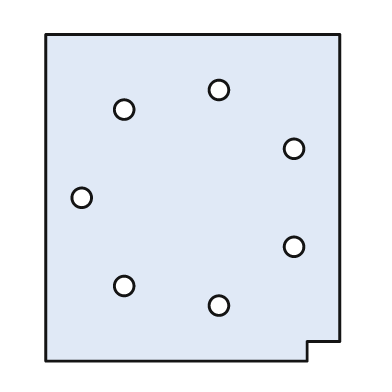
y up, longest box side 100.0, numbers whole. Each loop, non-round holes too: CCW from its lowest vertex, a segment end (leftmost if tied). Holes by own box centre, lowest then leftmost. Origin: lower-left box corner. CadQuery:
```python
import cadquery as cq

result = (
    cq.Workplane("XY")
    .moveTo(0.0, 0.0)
    .lineTo(80.0, 0.0)
    .lineTo(80.0, 6.0)
    .lineTo(90.0, 6.0)
    .lineTo(90.0, 100.0)
    .lineTo(0.0, 100.0)
    .close()
    .moveTo(53.0, 17.0)
    .circle(3.0)
    .moveTo(24.0, 23.0)
    .circle(3.0)
    .moveTo(76.0, 35.0)
    .circle(3.0)
    .moveTo(11.0, 50.0)
    .circle(3.0)
    .moveTo(76.0, 65.0)
    .circle(3.0)
    .moveTo(24.0, 77.0)
    .circle(3.0)
    .moveTo(53.0, 83.0)
    .circle(3.0)
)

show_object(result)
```